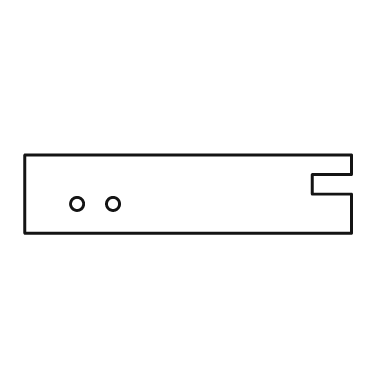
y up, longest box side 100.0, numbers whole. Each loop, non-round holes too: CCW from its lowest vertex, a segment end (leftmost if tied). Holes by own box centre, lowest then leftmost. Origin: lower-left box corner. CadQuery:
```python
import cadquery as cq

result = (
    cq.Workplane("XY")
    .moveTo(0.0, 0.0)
    .lineTo(100.0, 0.0)
    .lineTo(100.0, 12.0)
    .lineTo(88.0, 12.0)
    .lineTo(88.0, 18.0)
    .lineTo(100.0, 18.0)
    .lineTo(100.0, 24.0)
    .lineTo(0.0, 24.0)
    .close()
    .moveTo(16.0, 9.0)
    .circle(2.0)
    .moveTo(27.0, 9.0)
    .circle(2.0)
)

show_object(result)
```